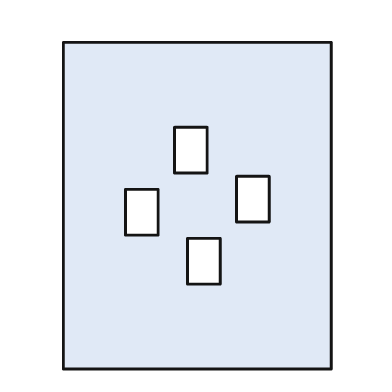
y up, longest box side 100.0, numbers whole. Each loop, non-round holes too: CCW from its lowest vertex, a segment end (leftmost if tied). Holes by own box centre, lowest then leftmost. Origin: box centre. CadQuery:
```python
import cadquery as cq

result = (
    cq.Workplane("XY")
    .moveTo(-41.0, -50.0)
    .lineTo(41.0, -50.0)
    .lineTo(41.0, 50.0)
    .lineTo(-41.0, 50.0)
    .close()
    .moveTo(-3.0, -24.0)
    .lineTo(7.0, -24.0)
    .lineTo(7.0, -10.0)
    .lineTo(-3.0, -10.0)
    .close()
    .moveTo(-22.0, -9.0)
    .lineTo(-12.0, -9.0)
    .lineTo(-12.0, 5.0)
    .lineTo(-22.0, 5.0)
    .close()
    .moveTo(12.0, -5.0)
    .lineTo(22.0, -5.0)
    .lineTo(22.0, 9.0)
    .lineTo(12.0, 9.0)
    .close()
    .moveTo(-7.0, 10.0)
    .lineTo(3.0, 10.0)
    .lineTo(3.0, 24.0)
    .lineTo(-7.0, 24.0)
    .close()
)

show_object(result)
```